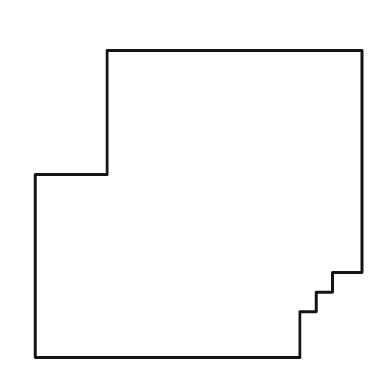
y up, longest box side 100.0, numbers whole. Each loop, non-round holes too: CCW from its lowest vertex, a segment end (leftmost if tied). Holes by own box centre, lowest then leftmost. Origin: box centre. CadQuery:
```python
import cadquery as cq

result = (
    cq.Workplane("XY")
    .moveTo(-50.0, -47.0)
    .lineTo(31.0, -47.0)
    .lineTo(31.0, -33.0)
    .lineTo(36.0, -33.0)
    .lineTo(36.0, -27.0)
    .lineTo(41.0, -27.0)
    .lineTo(41.0, -21.0)
    .lineTo(50.0, -21.0)
    .lineTo(50.0, 47.0)
    .lineTo(-28.0, 47.0)
    .lineTo(-28.0, 9.0)
    .lineTo(-50.0, 9.0)
    .close()
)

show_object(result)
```